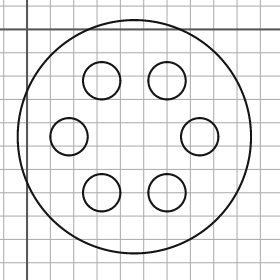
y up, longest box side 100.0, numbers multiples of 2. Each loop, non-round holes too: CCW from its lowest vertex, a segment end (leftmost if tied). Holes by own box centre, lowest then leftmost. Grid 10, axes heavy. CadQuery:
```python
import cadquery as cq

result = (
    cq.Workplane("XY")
    .moveTo(46.0, -46.0)
    .circle(50.0)
    .moveTo(32.0, -70.0)
    .circle(8.0)
    .moveTo(60.0, -70.0)
    .circle(8.0)
    .moveTo(18.0, -46.0)
    .circle(8.0)
    .moveTo(74.0, -46.0)
    .circle(8.0)
    .moveTo(32.0, -22.0)
    .circle(8.0)
    .moveTo(60.0, -22.0)
    .circle(8.0)
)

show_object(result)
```